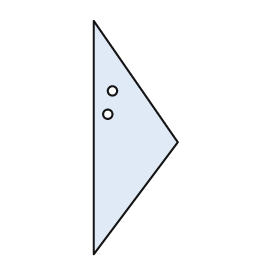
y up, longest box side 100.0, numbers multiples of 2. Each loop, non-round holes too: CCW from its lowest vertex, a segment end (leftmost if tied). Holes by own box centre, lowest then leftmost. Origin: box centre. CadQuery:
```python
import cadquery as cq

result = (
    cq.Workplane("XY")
    .moveTo(-18.0, -50.0)
    .lineTo(18.0, -2.0)
    .lineTo(-18.0, 50.0)
    .close()
    .moveTo(-12.0, 10.0)
    .circle(2.0)
    .moveTo(-10.0, 20.0)
    .circle(2.0)
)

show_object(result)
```